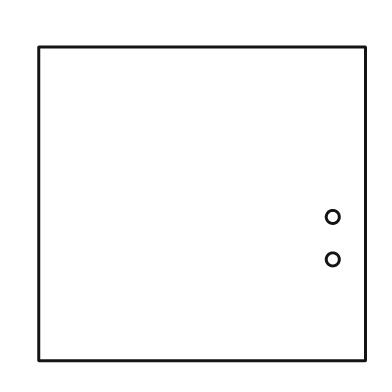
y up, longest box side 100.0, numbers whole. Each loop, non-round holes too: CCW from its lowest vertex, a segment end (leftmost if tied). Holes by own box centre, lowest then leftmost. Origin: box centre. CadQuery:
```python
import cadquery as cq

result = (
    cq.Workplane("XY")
    .moveTo(-50.0, -48.0)
    .lineTo(50.0, -48.0)
    .lineTo(50.0, 48.0)
    .lineTo(-50.0, 48.0)
    .close()
    .moveTo(40.0, -17.0)
    .circle(2.0)
    .moveTo(40.0, -4.0)
    .circle(2.0)
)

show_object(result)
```